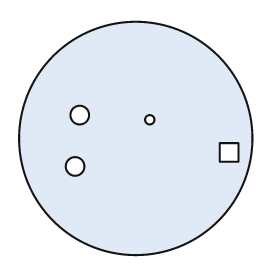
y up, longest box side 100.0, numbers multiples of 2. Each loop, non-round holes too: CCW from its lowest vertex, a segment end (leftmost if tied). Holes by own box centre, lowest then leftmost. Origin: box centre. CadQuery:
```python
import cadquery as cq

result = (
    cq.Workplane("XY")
    .moveTo(0.0, 0.0)
    .circle(50.0)
    .moveTo(-26.0, -12.0)
    .circle(4.0)
    .moveTo(36.0, -10.0)
    .lineTo(44.0, -10.0)
    .lineTo(44.0, -2.0)
    .lineTo(36.0, -2.0)
    .close()
    .moveTo(6.0, 8.0)
    .circle(2.0)
    .moveTo(-24.0, 10.0)
    .circle(4.0)
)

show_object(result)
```